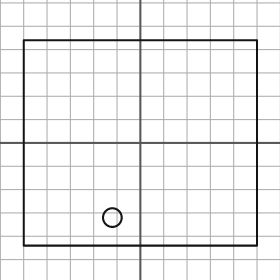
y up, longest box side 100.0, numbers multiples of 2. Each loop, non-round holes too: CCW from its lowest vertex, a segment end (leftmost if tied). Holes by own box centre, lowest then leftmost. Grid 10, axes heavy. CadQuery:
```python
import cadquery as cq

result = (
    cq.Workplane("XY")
    .moveTo(-50.0, -44.0)
    .lineTo(50.0, -44.0)
    .lineTo(50.0, 44.0)
    .lineTo(-50.0, 44.0)
    .close()
    .moveTo(-12.0, -32.0)
    .circle(4.0)
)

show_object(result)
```